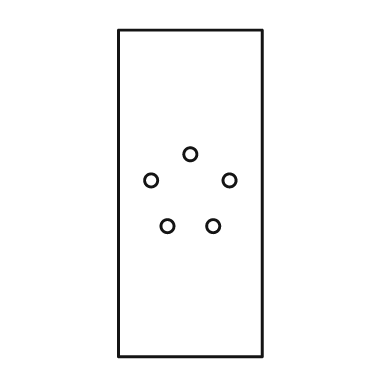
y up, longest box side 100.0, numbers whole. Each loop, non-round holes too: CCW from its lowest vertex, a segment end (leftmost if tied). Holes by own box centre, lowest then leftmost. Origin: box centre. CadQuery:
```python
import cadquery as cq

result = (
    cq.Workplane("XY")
    .moveTo(-22.0, -50.0)
    .lineTo(22.0, -50.0)
    .lineTo(22.0, 50.0)
    .lineTo(-22.0, 50.0)
    .close()
    .moveTo(-7.0, -10.0)
    .circle(2.0)
    .moveTo(7.0, -10.0)
    .circle(2.0)
    .moveTo(-12.0, 4.0)
    .circle(2.0)
    .moveTo(12.0, 4.0)
    .circle(2.0)
    .moveTo(0.0, 12.0)
    .circle(2.0)
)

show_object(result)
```